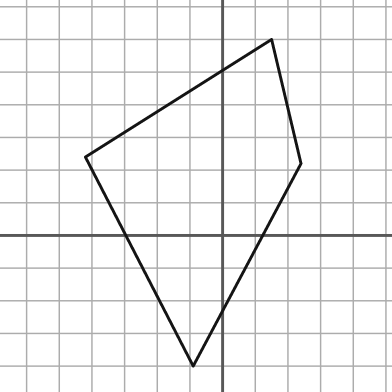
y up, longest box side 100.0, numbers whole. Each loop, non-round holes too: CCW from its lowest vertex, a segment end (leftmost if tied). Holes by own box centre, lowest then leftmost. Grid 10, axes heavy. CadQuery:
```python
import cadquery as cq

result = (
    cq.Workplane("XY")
    .moveTo(-9.0, -40.0)
    .lineTo(24.0, 22.0)
    .lineTo(15.0, 60.0)
    .lineTo(-42.0, 24.0)
    .close()
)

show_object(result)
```